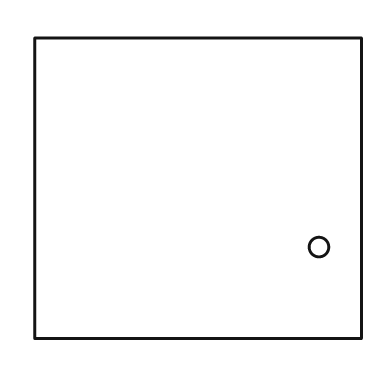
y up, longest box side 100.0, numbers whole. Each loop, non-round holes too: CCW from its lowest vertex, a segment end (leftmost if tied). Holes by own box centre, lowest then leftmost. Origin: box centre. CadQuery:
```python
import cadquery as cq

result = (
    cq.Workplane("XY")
    .moveTo(-50.0, -46.0)
    .lineTo(50.0, -46.0)
    .lineTo(50.0, 46.0)
    .lineTo(-50.0, 46.0)
    .close()
    .moveTo(37.0, -18.0)
    .circle(3.0)
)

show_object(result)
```